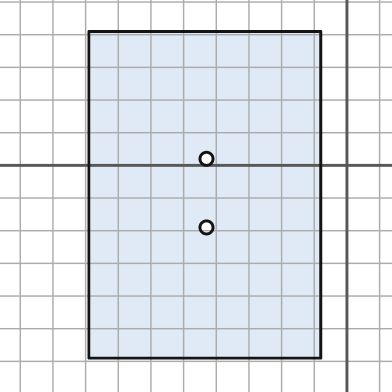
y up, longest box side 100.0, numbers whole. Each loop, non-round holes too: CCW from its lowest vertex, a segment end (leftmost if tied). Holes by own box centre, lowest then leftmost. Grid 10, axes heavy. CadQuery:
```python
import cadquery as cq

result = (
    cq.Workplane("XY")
    .moveTo(-79.0, -59.0)
    .lineTo(-8.0, -59.0)
    .lineTo(-8.0, 41.0)
    .lineTo(-79.0, 41.0)
    .close()
    .moveTo(-43.0, -19.0)
    .circle(2.0)
    .moveTo(-43.0, 2.0)
    .circle(2.0)
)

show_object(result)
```